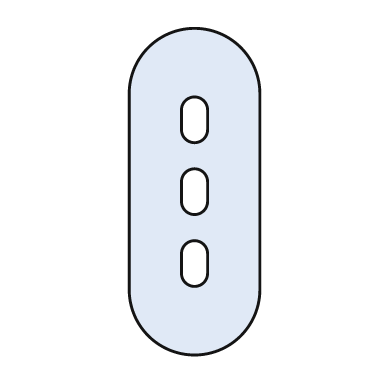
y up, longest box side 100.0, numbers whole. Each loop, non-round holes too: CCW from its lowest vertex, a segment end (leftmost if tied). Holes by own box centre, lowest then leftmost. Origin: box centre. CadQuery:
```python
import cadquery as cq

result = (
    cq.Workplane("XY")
    .moveTo(-20.0, -30.0)
    .threePointArc((0.0, -50.0), (20.0, -30.0))
    .lineTo(20.0, 30.0)
    .threePointArc((0.0, 50.0), (-20.0, 30.0))
    .close()
    .moveTo(-4.0, -25.0)
    .threePointArc((0.0, -29.0), (4.0, -25.0))
    .lineTo(4.0, -19.0)
    .threePointArc((0.0, -15.0), (-4.0, -19.0))
    .close()
    .moveTo(-4.0, -3.0)
    .threePointArc((0.0, -7.0), (4.0, -3.0))
    .lineTo(4.0, 3.0)
    .threePointArc((0.0, 7.0), (-4.0, 3.0))
    .close()
    .moveTo(-4.0, 19.0)
    .threePointArc((0.0, 15.0), (4.0, 19.0))
    .lineTo(4.0, 25.0)
    .threePointArc((0.0, 29.0), (-4.0, 25.0))
    .close()
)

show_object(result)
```